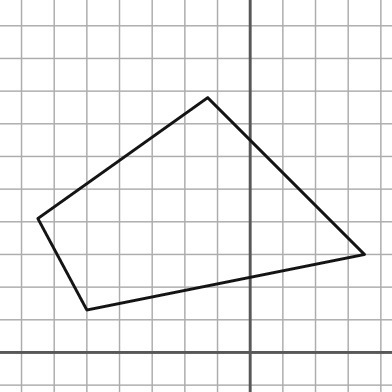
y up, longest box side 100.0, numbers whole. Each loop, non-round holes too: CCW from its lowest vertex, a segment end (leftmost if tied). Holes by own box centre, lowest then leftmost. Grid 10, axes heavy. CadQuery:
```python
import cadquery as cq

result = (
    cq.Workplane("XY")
    .moveTo(-50.0, 13.0)
    .lineTo(35.0, 30.0)
    .lineTo(-13.0, 78.0)
    .lineTo(-65.0, 41.0)
    .close()
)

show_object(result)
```